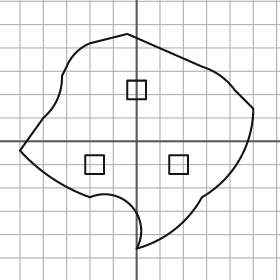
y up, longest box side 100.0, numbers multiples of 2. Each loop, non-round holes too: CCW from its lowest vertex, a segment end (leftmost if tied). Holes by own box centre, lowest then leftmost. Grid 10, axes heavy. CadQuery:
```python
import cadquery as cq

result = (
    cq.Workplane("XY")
    .moveTo(0.0, -46.0)
    .threePointArc((16.0, -38.0), (28.0, -24.0))
    .threePointArc((44.0, -8.0), (50.0, 14.0))
    .lineTo(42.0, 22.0)
    .threePointArc((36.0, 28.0), (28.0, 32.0))
    .lineTo(-4.0, 46.0)
    .lineTo(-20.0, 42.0)
    .threePointArc((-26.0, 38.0), (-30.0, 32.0))
    .lineTo(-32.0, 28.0)
    .threePointArc((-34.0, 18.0), (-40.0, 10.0))
    .lineTo(-50.0, -4.0)
    .threePointArc((-36.0, -16.0), (-20.0, -24.0))
    .threePointArc((-2.0, -28.0), (0.0, -46.0))
    .close()
    .moveTo(-22.0, -14.0)
    .lineTo(-14.0, -14.0)
    .lineTo(-14.0, -6.0)
    .lineTo(-22.0, -6.0)
    .close()
    .moveTo(14.0, -14.0)
    .lineTo(22.0, -14.0)
    .lineTo(22.0, -6.0)
    .lineTo(14.0, -6.0)
    .close()
    .moveTo(-4.0, 18.0)
    .lineTo(4.0, 18.0)
    .lineTo(4.0, 26.0)
    .lineTo(-4.0, 26.0)
    .close()
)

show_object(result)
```